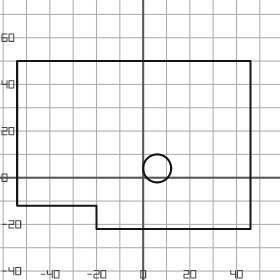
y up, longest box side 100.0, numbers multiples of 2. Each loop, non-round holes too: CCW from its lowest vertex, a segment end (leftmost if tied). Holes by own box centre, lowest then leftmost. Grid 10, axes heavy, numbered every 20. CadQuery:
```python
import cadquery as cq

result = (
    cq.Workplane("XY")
    .moveTo(-20.0, -22.0)
    .lineTo(46.0, -22.0)
    .lineTo(46.0, 50.0)
    .lineTo(-54.0, 50.0)
    .lineTo(-54.0, -12.0)
    .lineTo(-20.0, -12.0)
    .close()
    .moveTo(6.0, 4.0)
    .circle(6.0)
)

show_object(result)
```